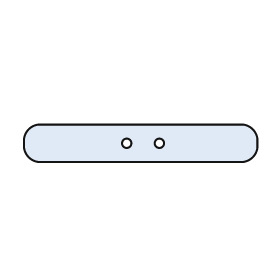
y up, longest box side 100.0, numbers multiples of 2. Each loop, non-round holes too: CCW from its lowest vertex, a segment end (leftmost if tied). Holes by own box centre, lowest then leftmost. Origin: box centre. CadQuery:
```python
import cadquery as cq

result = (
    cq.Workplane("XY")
    .moveTo(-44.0, -8.0)
    .lineTo(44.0, -8.0)
    .threePointArc((48.0, -6.0), (50.0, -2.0))
    .lineTo(50.0, 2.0)
    .threePointArc((48.0, 6.0), (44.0, 8.0))
    .lineTo(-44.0, 8.0)
    .threePointArc((-48.0, 6.0), (-50.0, 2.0))
    .lineTo(-50.0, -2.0)
    .threePointArc((-48.0, -6.0), (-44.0, -8.0))
    .close()
    .moveTo(-6.0, 0.0)
    .circle(2.0)
    .moveTo(8.0, 0.0)
    .circle(2.0)
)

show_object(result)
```